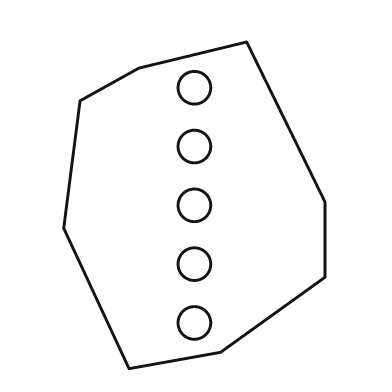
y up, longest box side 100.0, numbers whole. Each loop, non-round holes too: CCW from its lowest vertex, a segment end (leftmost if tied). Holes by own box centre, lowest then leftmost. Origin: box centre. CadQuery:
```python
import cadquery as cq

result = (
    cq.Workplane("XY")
    .moveTo(-20.0, -50.0)
    .lineTo(8.0, -45.0)
    .lineTo(40.0, -22.0)
    .lineTo(40.0, 1.0)
    .lineTo(16.0, 50.0)
    .lineTo(-17.0, 42.0)
    .lineTo(-35.0, 32.0)
    .lineTo(-40.0, -7.0)
    .close()
    .moveTo(0.0, -36.0)
    .circle(5.0)
    .moveTo(0.0, -18.0)
    .circle(5.0)
    .moveTo(0.0, 0.0)
    .circle(5.0)
    .moveTo(0.0, 18.0)
    .circle(5.0)
    .moveTo(0.0, 36.0)
    .circle(5.0)
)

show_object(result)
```